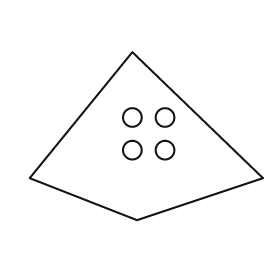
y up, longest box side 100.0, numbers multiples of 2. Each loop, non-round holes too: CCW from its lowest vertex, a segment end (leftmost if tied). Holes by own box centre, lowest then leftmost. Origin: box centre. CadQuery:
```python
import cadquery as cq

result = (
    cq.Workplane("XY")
    .moveTo(-4.0, -36.0)
    .lineTo(50.0, -18.0)
    .lineTo(-6.0, 36.0)
    .lineTo(-50.0, -18.0)
    .close()
    .moveTo(-6.0, -6.0)
    .circle(4.0)
    .moveTo(8.0, -6.0)
    .circle(4.0)
    .moveTo(-6.0, 8.0)
    .circle(4.0)
    .moveTo(8.0, 8.0)
    .circle(4.0)
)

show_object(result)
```